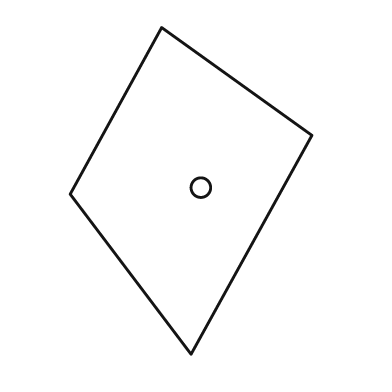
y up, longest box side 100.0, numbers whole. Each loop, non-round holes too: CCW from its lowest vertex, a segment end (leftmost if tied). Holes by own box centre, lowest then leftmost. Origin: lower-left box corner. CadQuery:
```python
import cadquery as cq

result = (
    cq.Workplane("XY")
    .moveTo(37.0, 0.0)
    .lineTo(74.0, 67.0)
    .lineTo(28.0, 100.0)
    .lineTo(0.0, 49.0)
    .close()
    .moveTo(40.0, 51.0)
    .circle(3.0)
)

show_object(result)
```